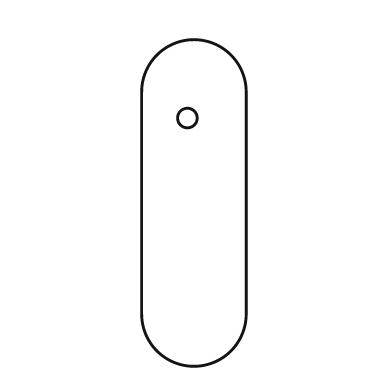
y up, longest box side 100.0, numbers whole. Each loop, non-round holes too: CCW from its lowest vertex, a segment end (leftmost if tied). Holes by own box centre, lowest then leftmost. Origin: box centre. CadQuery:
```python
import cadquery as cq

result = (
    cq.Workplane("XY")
    .moveTo(-16.0, -34.0)
    .threePointArc((0.0, -50.0), (16.0, -34.0))
    .lineTo(16.0, 34.0)
    .threePointArc((0.0, 50.0), (-16.0, 34.0))
    .close()
    .moveTo(-2.0, 26.0)
    .circle(3.0)
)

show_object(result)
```